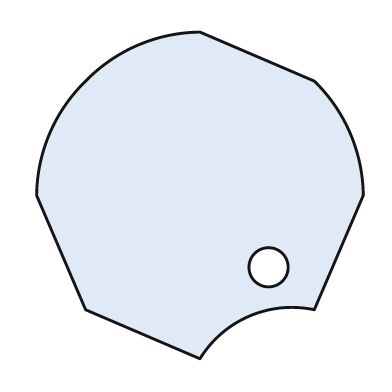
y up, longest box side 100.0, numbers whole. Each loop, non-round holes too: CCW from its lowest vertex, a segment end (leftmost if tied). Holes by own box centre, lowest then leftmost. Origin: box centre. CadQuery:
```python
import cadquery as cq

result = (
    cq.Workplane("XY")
    .moveTo(0.0, -50.0)
    .threePointArc((15.0, -37.0), (35.0, -35.0))
    .lineTo(50.0, 0.0)
    .threePointArc((46.0, 19.0), (35.0, 35.0))
    .lineTo(0.0, 50.0)
    .threePointArc((-19.0, 46.0), (-35.0, 35.0))
    .threePointArc((-46.0, 19.0), (-50.0, 0.0))
    .lineTo(-35.0, -35.0)
    .close()
    .moveTo(21.0, -22.0)
    .circle(6.0)
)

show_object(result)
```